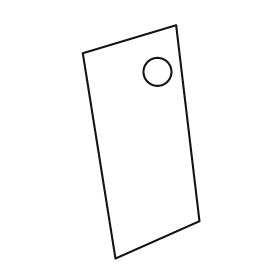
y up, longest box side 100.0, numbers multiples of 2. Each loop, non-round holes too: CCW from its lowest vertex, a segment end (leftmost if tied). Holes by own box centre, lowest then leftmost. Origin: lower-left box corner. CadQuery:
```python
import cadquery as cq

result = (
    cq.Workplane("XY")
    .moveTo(14.0, 0.0)
    .lineTo(50.0, 16.0)
    .lineTo(40.0, 100.0)
    .lineTo(0.0, 88.0)
    .close()
    .moveTo(32.0, 80.0)
    .circle(6.0)
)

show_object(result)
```